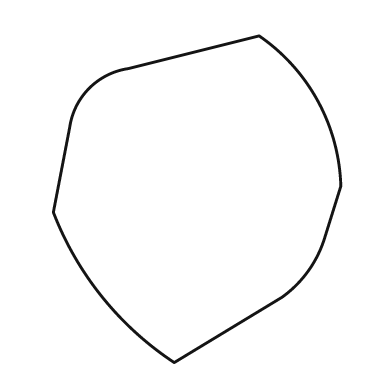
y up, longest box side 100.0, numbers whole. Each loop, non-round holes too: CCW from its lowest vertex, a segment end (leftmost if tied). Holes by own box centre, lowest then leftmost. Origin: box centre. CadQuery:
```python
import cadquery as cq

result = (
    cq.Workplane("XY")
    .moveTo(-7.0, -50.0)
    .lineTo(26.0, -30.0)
    .threePointArc((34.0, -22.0), (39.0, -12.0))
    .lineTo(44.0, 4.0)
    .threePointArc((37.0, 30.0), (19.0, 50.0))
    .lineTo(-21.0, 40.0)
    .threePointArc((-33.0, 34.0), (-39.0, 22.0))
    .lineTo(-44.0, -4.0)
    .threePointArc((-29.0, -30.0), (-7.0, -50.0))
    .close()
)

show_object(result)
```